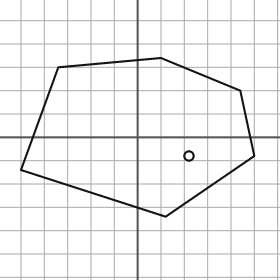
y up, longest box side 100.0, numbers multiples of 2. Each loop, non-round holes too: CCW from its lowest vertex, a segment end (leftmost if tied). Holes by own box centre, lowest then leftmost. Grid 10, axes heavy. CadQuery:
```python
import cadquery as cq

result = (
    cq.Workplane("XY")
    .moveTo(12.0, -34.0)
    .lineTo(50.0, -8.0)
    .lineTo(44.0, 20.0)
    .lineTo(10.0, 34.0)
    .lineTo(-34.0, 30.0)
    .lineTo(-50.0, -14.0)
    .close()
    .moveTo(22.0, -8.0)
    .circle(2.0)
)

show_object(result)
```